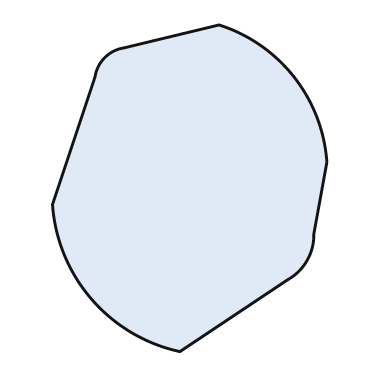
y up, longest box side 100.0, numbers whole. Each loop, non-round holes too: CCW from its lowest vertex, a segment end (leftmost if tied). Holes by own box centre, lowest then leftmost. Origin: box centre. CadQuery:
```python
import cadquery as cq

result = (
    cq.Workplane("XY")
    .moveTo(-3.0, -50.0)
    .lineTo(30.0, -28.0)
    .threePointArc((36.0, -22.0), (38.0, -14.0))
    .lineTo(42.0, 8.0)
    .threePointArc((32.0, 34.0), (9.0, 50.0))
    .lineTo(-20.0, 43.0)
    .threePointArc((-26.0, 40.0), (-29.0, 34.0))
    .lineTo(-42.0, -5.0)
    .threePointArc((-30.0, -34.0), (-3.0, -50.0))
    .close()
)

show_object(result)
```